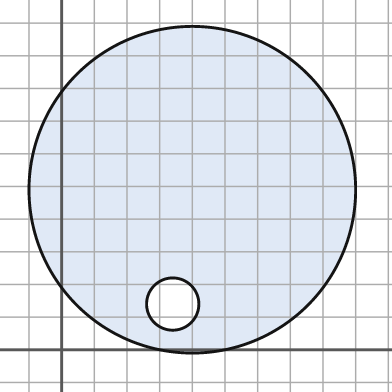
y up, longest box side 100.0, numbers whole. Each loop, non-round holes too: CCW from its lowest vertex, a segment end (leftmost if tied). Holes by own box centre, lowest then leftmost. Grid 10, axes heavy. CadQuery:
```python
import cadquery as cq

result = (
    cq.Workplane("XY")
    .moveTo(40.0, 49.0)
    .circle(50.0)
    .moveTo(34.0, 14.0)
    .circle(8.0)
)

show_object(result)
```